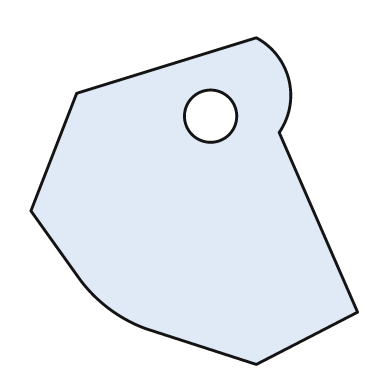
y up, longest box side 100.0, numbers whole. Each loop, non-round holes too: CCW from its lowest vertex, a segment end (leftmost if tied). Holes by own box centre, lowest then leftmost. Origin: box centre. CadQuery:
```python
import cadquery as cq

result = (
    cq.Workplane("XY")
    .moveTo(19.0, -50.0)
    .lineTo(50.0, -34.0)
    .lineTo(26.0, 21.0)
    .threePointArc((29.0, 37.0), (19.0, 50.0))
    .lineTo(-36.0, 33.0)
    .lineTo(-50.0, -3.0)
    .lineTo(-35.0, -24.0)
    .threePointArc((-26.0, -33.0), (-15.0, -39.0))
    .close()
    .moveTo(5.0, 26.0)
    .circle(8.0)
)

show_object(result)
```